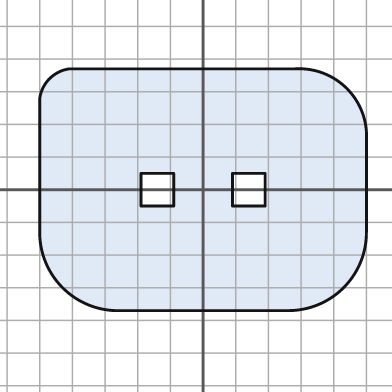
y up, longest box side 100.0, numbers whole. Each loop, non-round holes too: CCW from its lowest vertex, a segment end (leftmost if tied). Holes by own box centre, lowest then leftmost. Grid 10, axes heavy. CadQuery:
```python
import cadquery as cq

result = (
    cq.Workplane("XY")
    .moveTo(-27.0, -37.0)
    .lineTo(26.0, -37.0)
    .threePointArc((43.0, -30.0), (50.0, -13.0))
    .lineTo(50.0, 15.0)
    .threePointArc((44.0, 31.0), (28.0, 37.0))
    .lineTo(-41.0, 37.0)
    .threePointArc((-47.0, 34.0), (-50.0, 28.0))
    .lineTo(-50.0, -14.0)
    .threePointArc((-43.0, -30.0), (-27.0, -37.0))
    .close()
    .moveTo(-19.0, -5.0)
    .lineTo(-9.0, -5.0)
    .lineTo(-9.0, 5.0)
    .lineTo(-19.0, 5.0)
    .close()
    .moveTo(9.0, -5.0)
    .lineTo(19.0, -5.0)
    .lineTo(19.0, 5.0)
    .lineTo(9.0, 5.0)
    .close()
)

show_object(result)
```